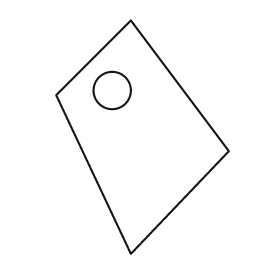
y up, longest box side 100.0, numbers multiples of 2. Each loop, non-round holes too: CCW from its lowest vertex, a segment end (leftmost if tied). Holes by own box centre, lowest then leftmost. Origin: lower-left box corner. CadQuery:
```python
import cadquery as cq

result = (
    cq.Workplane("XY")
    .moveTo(32.0, 0.0)
    .lineTo(74.0, 44.0)
    .lineTo(32.0, 100.0)
    .lineTo(0.0, 68.0)
    .close()
    .moveTo(24.0, 70.0)
    .circle(8.0)
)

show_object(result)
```